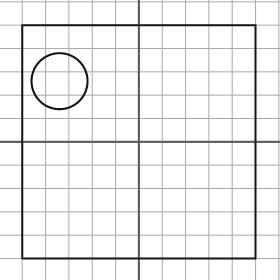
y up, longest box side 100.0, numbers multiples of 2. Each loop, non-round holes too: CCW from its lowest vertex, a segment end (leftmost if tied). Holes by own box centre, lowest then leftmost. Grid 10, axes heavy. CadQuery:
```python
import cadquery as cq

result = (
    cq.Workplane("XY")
    .moveTo(-50.0, -50.0)
    .lineTo(50.0, -50.0)
    .lineTo(50.0, 50.0)
    .lineTo(-50.0, 50.0)
    .close()
    .moveTo(-34.0, 26.0)
    .circle(12.0)
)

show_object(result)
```